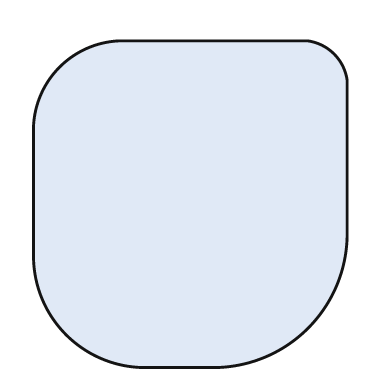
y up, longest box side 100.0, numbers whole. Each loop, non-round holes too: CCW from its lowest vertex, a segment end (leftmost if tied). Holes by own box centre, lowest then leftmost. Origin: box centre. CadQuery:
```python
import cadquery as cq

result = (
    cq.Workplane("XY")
    .moveTo(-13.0, -50.0)
    .lineTo(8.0, -50.0)
    .threePointArc((36.0, -38.0), (48.0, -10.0))
    .lineTo(48.0, 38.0)
    .threePointArc((44.0, 46.0), (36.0, 50.0))
    .lineTo(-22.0, 50.0)
    .threePointArc((-40.0, 42.0), (-48.0, 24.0))
    .lineTo(-48.0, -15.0)
    .threePointArc((-38.0, -40.0), (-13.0, -50.0))
    .close()
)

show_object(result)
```